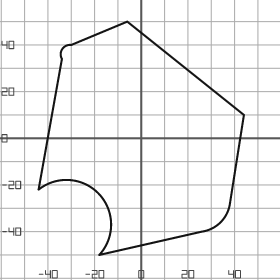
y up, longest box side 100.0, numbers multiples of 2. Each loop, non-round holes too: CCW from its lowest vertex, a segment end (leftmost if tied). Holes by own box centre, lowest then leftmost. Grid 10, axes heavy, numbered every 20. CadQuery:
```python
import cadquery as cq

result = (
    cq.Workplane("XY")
    .moveTo(-18.0, -50.0)
    .lineTo(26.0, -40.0)
    .threePointArc((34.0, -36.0), (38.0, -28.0))
    .lineTo(44.0, 10.0)
    .lineTo(-6.0, 50.0)
    .lineTo(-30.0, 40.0)
    .threePointArc((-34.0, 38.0), (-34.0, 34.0))
    .lineTo(-44.0, -22.0)
    .threePointArc((-18.0, -24.0), (-18.0, -50.0))
    .close()
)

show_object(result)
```